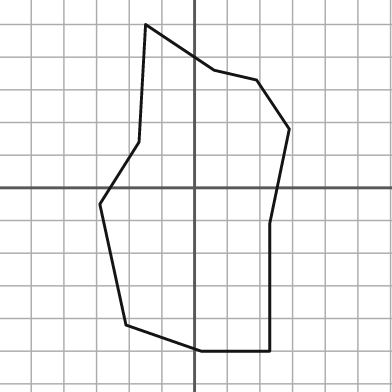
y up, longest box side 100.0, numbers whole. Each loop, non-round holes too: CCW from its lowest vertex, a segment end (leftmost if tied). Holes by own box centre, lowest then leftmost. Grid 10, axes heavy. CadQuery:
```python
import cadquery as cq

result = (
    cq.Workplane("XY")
    .moveTo(2.0, -50.0)
    .lineTo(23.0, -50.0)
    .lineTo(23.0, -11.0)
    .lineTo(29.0, 18.0)
    .lineTo(19.0, 33.0)
    .lineTo(6.0, 36.0)
    .lineTo(-15.0, 50.0)
    .lineTo(-17.0, 14.0)
    .lineTo(-29.0, -5.0)
    .lineTo(-21.0, -42.0)
    .close()
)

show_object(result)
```